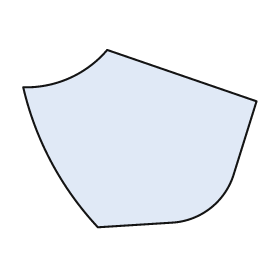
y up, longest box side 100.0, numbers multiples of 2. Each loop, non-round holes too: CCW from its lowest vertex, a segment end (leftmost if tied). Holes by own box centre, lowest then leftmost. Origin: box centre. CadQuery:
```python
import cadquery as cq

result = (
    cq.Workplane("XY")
    .moveTo(-18.0, -38.0)
    .lineTo(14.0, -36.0)
    .threePointArc((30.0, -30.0), (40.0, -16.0))
    .lineTo(50.0, 16.0)
    .lineTo(-14.0, 38.0)
    .threePointArc((-30.0, 26.0), (-50.0, 22.0))
    .threePointArc((-38.0, -10.0), (-18.0, -38.0))
    .close()
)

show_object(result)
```